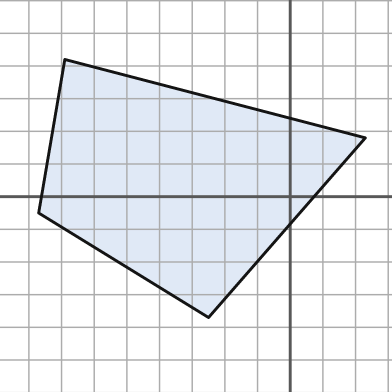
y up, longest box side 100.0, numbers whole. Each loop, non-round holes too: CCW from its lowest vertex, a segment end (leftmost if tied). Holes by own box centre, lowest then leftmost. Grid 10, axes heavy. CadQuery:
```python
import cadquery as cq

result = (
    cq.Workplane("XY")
    .moveTo(-25.0, -37.0)
    .lineTo(23.0, 18.0)
    .lineTo(-69.0, 42.0)
    .lineTo(-77.0, -5.0)
    .close()
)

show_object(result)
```